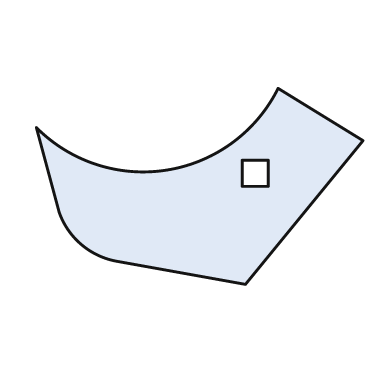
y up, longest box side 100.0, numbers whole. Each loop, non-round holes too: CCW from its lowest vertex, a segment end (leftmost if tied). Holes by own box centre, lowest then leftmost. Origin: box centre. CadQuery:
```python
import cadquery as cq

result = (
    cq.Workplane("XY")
    .moveTo(14.0, -30.0)
    .lineTo(50.0, 14.0)
    .lineTo(24.0, 30.0)
    .threePointArc((-10.0, 5.0), (-50.0, 18.0))
    .lineTo(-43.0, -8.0)
    .threePointArc((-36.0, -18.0), (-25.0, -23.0))
    .close()
    .moveTo(13.0, 0.0)
    .lineTo(21.0, 0.0)
    .lineTo(21.0, 8.0)
    .lineTo(13.0, 8.0)
    .close()
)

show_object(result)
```